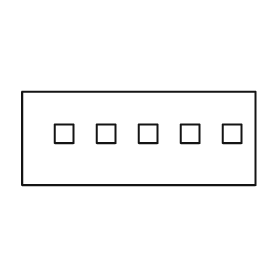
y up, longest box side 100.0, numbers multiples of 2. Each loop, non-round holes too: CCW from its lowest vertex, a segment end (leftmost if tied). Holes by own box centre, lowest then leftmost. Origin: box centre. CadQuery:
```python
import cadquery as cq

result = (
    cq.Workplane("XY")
    .moveTo(-50.0, -20.0)
    .lineTo(50.0, -20.0)
    .lineTo(50.0, 20.0)
    .lineTo(-50.0, 20.0)
    .close()
    .moveTo(-36.0, -2.0)
    .lineTo(-28.0, -2.0)
    .lineTo(-28.0, 6.0)
    .lineTo(-36.0, 6.0)
    .close()
    .moveTo(-18.0, -2.0)
    .lineTo(-10.0, -2.0)
    .lineTo(-10.0, 6.0)
    .lineTo(-18.0, 6.0)
    .close()
    .moveTo(0.0, -2.0)
    .lineTo(8.0, -2.0)
    .lineTo(8.0, 6.0)
    .lineTo(0.0, 6.0)
    .close()
    .moveTo(18.0, -2.0)
    .lineTo(26.0, -2.0)
    .lineTo(26.0, 6.0)
    .lineTo(18.0, 6.0)
    .close()
    .moveTo(36.0, -2.0)
    .lineTo(44.0, -2.0)
    .lineTo(44.0, 6.0)
    .lineTo(36.0, 6.0)
    .close()
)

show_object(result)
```